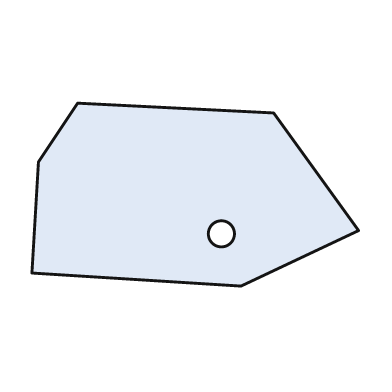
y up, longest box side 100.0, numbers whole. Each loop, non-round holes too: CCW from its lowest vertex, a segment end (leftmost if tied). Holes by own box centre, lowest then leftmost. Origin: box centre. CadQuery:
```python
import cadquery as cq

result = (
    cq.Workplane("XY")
    .moveTo(14.0, -28.0)
    .lineTo(50.0, -11.0)
    .lineTo(24.0, 25.0)
    .lineTo(-36.0, 28.0)
    .lineTo(-48.0, 10.0)
    .lineTo(-50.0, -24.0)
    .close()
    .moveTo(8.0, -12.0)
    .circle(4.0)
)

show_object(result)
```